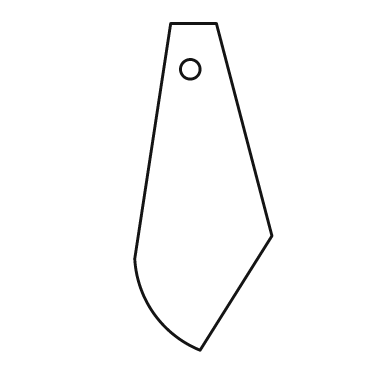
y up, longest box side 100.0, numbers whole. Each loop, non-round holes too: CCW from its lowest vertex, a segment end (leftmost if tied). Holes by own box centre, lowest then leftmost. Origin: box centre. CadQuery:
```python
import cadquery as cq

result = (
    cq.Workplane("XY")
    .moveTo(-1.0, -50.0)
    .lineTo(21.0, -15.0)
    .lineTo(4.0, 50.0)
    .lineTo(-10.0, 50.0)
    .lineTo(-21.0, -22.0)
    .threePointArc((-15.0, -39.0), (-1.0, -50.0))
    .close()
    .moveTo(-4.0, 36.0)
    .circle(3.0)
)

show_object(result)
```